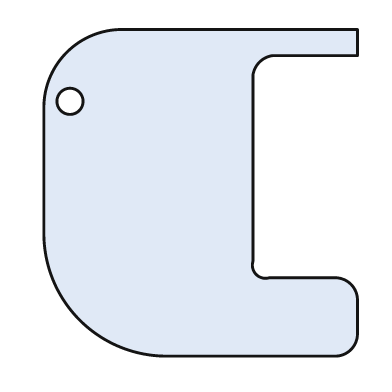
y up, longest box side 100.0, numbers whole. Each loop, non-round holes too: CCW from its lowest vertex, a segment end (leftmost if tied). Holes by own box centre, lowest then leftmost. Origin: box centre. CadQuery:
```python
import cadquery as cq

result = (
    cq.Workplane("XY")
    .moveTo(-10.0, -50.0)
    .lineTo(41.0, -50.0)
    .threePointArc((46.0, -48.0), (48.0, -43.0))
    .lineTo(48.0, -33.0)
    .threePointArc((46.0, -28.0), (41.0, -26.0))
    .lineTo(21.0, -26.0)
    .threePointArc((17.0, -25.0), (16.0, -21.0))
    .lineTo(16.0, 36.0)
    .threePointArc((18.0, 40.0), (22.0, 42.0))
    .lineTo(48.0, 42.0)
    .lineTo(48.0, 50.0)
    .lineTo(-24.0, 50.0)
    .threePointArc((-41.0, 43.0), (-48.0, 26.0))
    .lineTo(-48.0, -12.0)
    .threePointArc((-37.0, -39.0), (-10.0, -50.0))
    .close()
    .moveTo(-40.0, 28.0)
    .circle(4.0)
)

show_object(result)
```